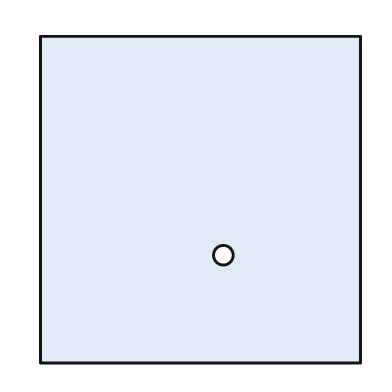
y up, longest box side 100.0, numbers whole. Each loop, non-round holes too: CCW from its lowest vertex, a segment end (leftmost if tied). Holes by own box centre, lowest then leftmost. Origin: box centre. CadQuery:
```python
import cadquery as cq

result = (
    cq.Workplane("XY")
    .moveTo(-49.0, -50.0)
    .lineTo(49.0, -50.0)
    .lineTo(49.0, 50.0)
    .lineTo(-49.0, 50.0)
    .close()
    .moveTo(7.0, -17.0)
    .circle(3.0)
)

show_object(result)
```